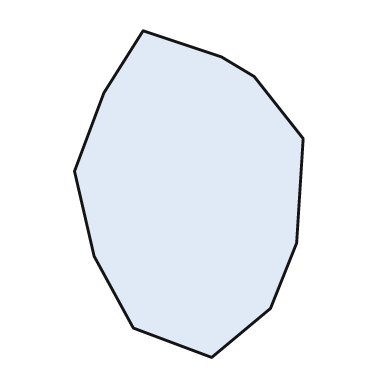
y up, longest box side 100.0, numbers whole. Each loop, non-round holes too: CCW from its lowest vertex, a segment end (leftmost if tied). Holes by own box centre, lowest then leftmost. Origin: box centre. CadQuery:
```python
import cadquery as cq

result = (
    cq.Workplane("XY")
    .moveTo(7.0, -50.0)
    .lineTo(25.0, -35.0)
    .lineTo(33.0, -15.0)
    .lineTo(35.0, 17.0)
    .lineTo(20.0, 36.0)
    .lineTo(10.0, 42.0)
    .lineTo(-14.0, 50.0)
    .lineTo(-26.0, 31.0)
    .lineTo(-35.0, 7.0)
    .lineTo(-29.0, -19.0)
    .lineTo(-17.0, -41.0)
    .close()
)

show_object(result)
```